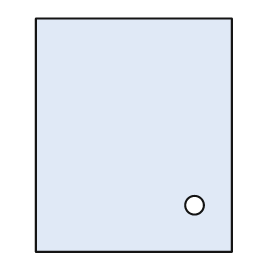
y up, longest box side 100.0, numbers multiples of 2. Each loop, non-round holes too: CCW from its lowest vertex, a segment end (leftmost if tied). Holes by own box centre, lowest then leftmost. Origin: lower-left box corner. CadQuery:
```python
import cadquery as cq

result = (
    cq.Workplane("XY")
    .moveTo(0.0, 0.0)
    .lineTo(84.0, 0.0)
    .lineTo(84.0, 100.0)
    .lineTo(0.0, 100.0)
    .close()
    .moveTo(68.0, 20.0)
    .circle(4.0)
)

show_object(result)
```